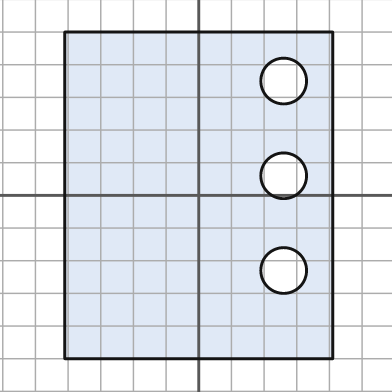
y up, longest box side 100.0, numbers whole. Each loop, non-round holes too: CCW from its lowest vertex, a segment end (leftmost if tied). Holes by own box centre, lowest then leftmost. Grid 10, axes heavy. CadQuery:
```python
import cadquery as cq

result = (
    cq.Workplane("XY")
    .moveTo(-41.0, -50.0)
    .lineTo(41.0, -50.0)
    .lineTo(41.0, 50.0)
    .lineTo(-41.0, 50.0)
    .close()
    .moveTo(26.0, -23.0)
    .circle(7.0)
    .moveTo(26.0, 6.0)
    .circle(7.0)
    .moveTo(26.0, 35.0)
    .circle(7.0)
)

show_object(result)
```